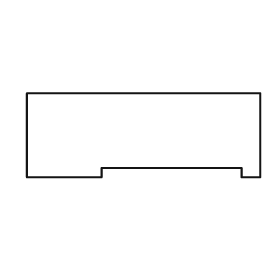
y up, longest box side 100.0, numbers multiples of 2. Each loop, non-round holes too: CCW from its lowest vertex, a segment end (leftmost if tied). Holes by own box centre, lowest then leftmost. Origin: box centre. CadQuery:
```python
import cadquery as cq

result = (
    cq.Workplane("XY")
    .moveTo(-50.0, -18.0)
    .lineTo(-18.0, -18.0)
    .lineTo(-18.0, -14.0)
    .lineTo(42.0, -14.0)
    .lineTo(42.0, -18.0)
    .lineTo(50.0, -18.0)
    .lineTo(50.0, 18.0)
    .lineTo(-50.0, 18.0)
    .close()
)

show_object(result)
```